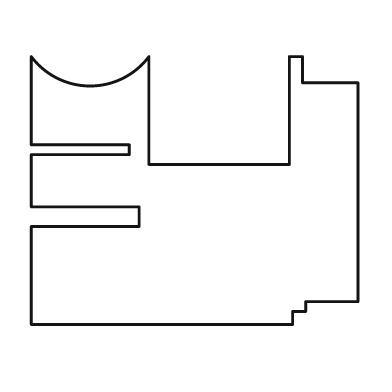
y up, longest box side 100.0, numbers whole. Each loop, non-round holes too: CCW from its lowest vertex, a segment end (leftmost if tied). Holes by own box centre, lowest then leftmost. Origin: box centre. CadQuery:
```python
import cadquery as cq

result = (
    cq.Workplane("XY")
    .moveTo(-50.0, -41.0)
    .lineTo(30.0, -41.0)
    .lineTo(30.0, -37.0)
    .lineTo(34.0, -37.0)
    .lineTo(34.0, -34.0)
    .lineTo(50.0, -34.0)
    .lineTo(50.0, 33.0)
    .lineTo(33.0, 33.0)
    .lineTo(33.0, 41.0)
    .lineTo(29.0, 41.0)
    .lineTo(29.0, 8.0)
    .lineTo(-14.0, 8.0)
    .lineTo(-14.0, 41.0)
    .threePointArc((-32.0, 32.0), (-50.0, 41.0))
    .lineTo(-50.0, 14.0)
    .lineTo(-20.0, 14.0)
    .lineTo(-20.0, 11.0)
    .lineTo(-50.0, 11.0)
    .lineTo(-50.0, -5.0)
    .lineTo(-17.0, -5.0)
    .lineTo(-17.0, -11.0)
    .lineTo(-50.0, -11.0)
    .close()
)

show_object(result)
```